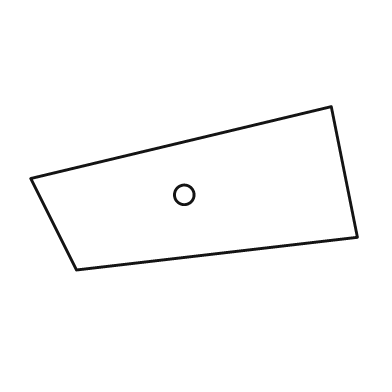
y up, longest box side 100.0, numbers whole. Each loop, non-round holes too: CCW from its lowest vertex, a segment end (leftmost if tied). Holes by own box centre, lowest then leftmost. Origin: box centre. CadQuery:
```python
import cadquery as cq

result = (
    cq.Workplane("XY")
    .moveTo(-36.0, -25.0)
    .lineTo(50.0, -15.0)
    .lineTo(42.0, 25.0)
    .lineTo(-50.0, 3.0)
    .close()
    .moveTo(-3.0, -2.0)
    .circle(3.0)
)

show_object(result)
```